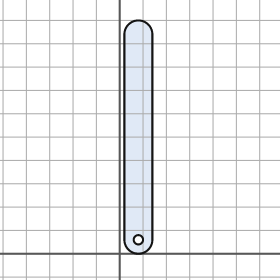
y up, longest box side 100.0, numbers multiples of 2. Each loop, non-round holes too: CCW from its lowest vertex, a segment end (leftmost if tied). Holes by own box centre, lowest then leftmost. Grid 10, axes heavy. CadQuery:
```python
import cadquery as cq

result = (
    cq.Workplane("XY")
    .moveTo(2.0, 6.0)
    .threePointArc((8.0, 0.0), (14.0, 6.0))
    .lineTo(14.0, 94.0)
    .threePointArc((8.0, 100.0), (2.0, 94.0))
    .close()
    .moveTo(8.0, 6.0)
    .circle(2.0)
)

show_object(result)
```